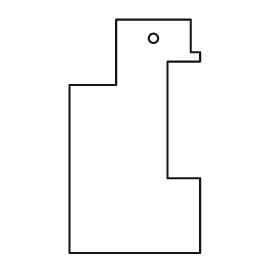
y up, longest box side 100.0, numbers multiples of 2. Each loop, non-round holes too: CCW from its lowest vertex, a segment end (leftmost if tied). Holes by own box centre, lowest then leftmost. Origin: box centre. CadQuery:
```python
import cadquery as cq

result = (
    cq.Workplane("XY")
    .moveTo(-28.0, -50.0)
    .lineTo(28.0, -50.0)
    .lineTo(28.0, -18.0)
    .lineTo(14.0, -18.0)
    .lineTo(14.0, 32.0)
    .lineTo(28.0, 32.0)
    .lineTo(28.0, 36.0)
    .lineTo(24.0, 36.0)
    .lineTo(24.0, 50.0)
    .lineTo(-8.0, 50.0)
    .lineTo(-8.0, 22.0)
    .lineTo(-28.0, 22.0)
    .close()
    .moveTo(8.0, 42.0)
    .circle(2.0)
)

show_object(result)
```